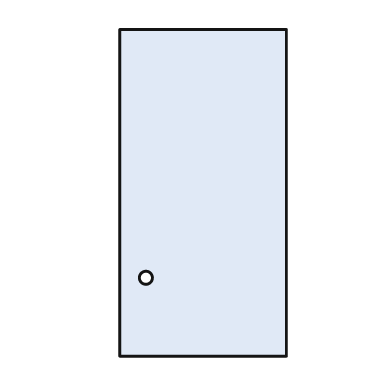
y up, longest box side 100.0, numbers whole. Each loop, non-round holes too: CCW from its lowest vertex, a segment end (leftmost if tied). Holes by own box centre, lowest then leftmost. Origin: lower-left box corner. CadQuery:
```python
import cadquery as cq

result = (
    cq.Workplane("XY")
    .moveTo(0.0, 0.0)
    .lineTo(51.0, 0.0)
    .lineTo(51.0, 100.0)
    .lineTo(0.0, 100.0)
    .close()
    .moveTo(8.0, 24.0)
    .circle(2.0)
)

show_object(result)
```